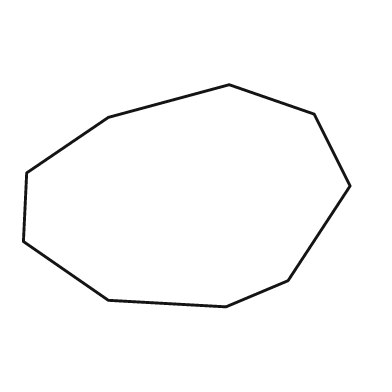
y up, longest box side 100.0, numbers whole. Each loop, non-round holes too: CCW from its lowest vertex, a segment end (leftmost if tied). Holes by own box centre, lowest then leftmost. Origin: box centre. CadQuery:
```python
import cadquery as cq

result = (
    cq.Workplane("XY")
    .moveTo(12.0, -34.0)
    .lineTo(31.0, -26.0)
    .lineTo(50.0, 3.0)
    .lineTo(39.0, 25.0)
    .lineTo(13.0, 34.0)
    .lineTo(-24.0, 24.0)
    .lineTo(-49.0, 7.0)
    .lineTo(-50.0, -14.0)
    .lineTo(-24.0, -32.0)
    .close()
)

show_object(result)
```